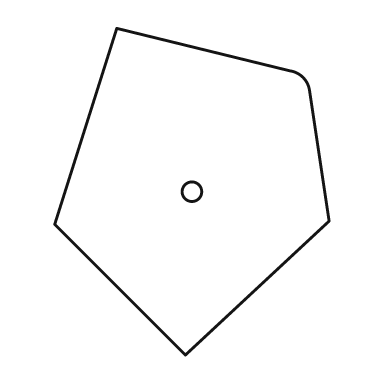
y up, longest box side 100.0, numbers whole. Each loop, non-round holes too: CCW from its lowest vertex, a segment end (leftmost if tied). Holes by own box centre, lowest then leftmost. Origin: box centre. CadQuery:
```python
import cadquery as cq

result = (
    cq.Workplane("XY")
    .moveTo(-2.0, -50.0)
    .lineTo(42.0, -9.0)
    .lineTo(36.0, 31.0)
    .threePointArc((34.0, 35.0), (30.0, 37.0))
    .lineTo(-23.0, 50.0)
    .lineTo(-42.0, -10.0)
    .close()
    .moveTo(0.0, 0.0)
    .circle(3.0)
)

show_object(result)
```